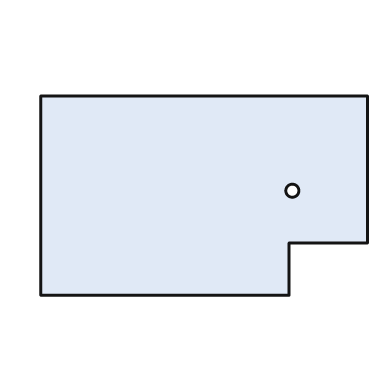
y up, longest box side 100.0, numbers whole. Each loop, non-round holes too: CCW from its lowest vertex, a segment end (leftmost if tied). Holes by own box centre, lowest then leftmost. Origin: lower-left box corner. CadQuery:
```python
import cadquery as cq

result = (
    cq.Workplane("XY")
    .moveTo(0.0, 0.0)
    .lineTo(76.0, 0.0)
    .lineTo(76.0, 16.0)
    .lineTo(100.0, 16.0)
    .lineTo(100.0, 61.0)
    .lineTo(0.0, 61.0)
    .close()
    .moveTo(77.0, 32.0)
    .circle(2.0)
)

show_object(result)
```